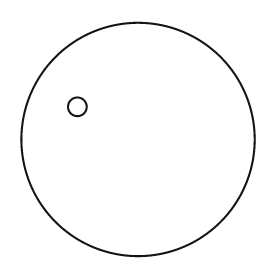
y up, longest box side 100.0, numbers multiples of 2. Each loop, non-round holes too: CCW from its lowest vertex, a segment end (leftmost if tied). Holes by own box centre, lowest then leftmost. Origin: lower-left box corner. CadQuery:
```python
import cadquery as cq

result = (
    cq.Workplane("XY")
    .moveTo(50.0, 50.0)
    .circle(50.0)
    .moveTo(24.0, 64.0)
    .circle(4.0)
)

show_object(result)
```